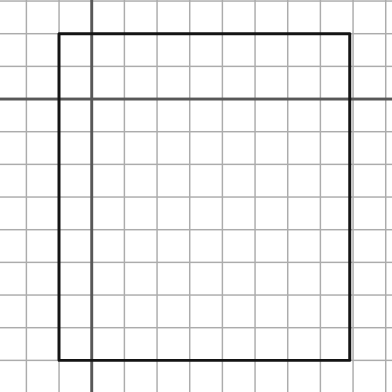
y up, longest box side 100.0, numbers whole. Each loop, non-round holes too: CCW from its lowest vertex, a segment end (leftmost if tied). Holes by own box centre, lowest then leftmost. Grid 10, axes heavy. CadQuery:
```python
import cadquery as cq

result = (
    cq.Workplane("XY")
    .moveTo(-10.0, -80.0)
    .lineTo(79.0, -80.0)
    .lineTo(79.0, 20.0)
    .lineTo(-10.0, 20.0)
    .close()
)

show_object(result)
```